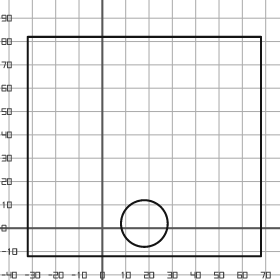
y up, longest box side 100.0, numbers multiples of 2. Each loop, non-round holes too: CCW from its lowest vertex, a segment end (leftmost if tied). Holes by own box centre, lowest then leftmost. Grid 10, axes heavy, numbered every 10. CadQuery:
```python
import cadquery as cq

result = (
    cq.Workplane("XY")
    .moveTo(-32.0, -12.0)
    .lineTo(68.0, -12.0)
    .lineTo(68.0, 82.0)
    .lineTo(-32.0, 82.0)
    .close()
    .moveTo(18.0, 2.0)
    .circle(10.0)
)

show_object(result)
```